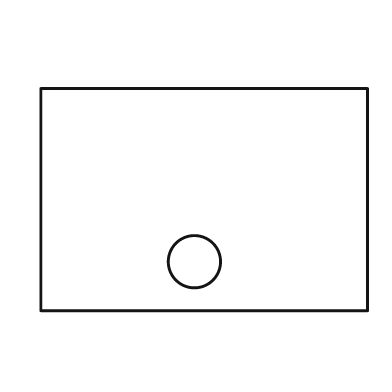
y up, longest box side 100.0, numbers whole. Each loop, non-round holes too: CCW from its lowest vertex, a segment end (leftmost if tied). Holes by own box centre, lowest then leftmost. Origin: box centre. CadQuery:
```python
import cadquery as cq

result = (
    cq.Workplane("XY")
    .moveTo(-50.0, -34.0)
    .lineTo(50.0, -34.0)
    .lineTo(50.0, 34.0)
    .lineTo(-50.0, 34.0)
    .close()
    .moveTo(-3.0, -19.0)
    .circle(8.0)
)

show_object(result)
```